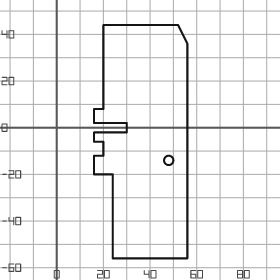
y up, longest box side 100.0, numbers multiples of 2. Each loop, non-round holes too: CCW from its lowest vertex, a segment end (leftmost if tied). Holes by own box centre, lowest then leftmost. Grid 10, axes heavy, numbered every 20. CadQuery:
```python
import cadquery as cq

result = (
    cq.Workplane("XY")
    .moveTo(24.0, -56.0)
    .lineTo(56.0, -56.0)
    .lineTo(56.0, 36.0)
    .lineTo(52.0, 44.0)
    .lineTo(20.0, 44.0)
    .lineTo(20.0, 8.0)
    .lineTo(16.0, 8.0)
    .lineTo(16.0, 2.0)
    .lineTo(30.0, 2.0)
    .lineTo(30.0, -2.0)
    .lineTo(16.0, -2.0)
    .lineTo(16.0, -6.0)
    .lineTo(20.0, -6.0)
    .lineTo(20.0, -12.0)
    .lineTo(16.0, -12.0)
    .lineTo(16.0, -20.0)
    .lineTo(24.0, -20.0)
    .close()
    .moveTo(48.0, -14.0)
    .circle(2.0)
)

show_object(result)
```